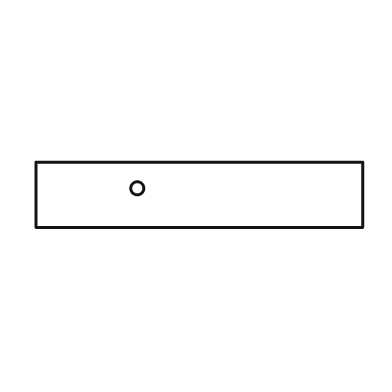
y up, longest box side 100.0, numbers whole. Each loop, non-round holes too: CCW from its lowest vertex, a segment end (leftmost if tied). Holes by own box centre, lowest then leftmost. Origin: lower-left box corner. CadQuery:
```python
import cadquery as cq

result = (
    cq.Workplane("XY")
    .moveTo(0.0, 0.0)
    .lineTo(100.0, 0.0)
    .lineTo(100.0, 20.0)
    .lineTo(0.0, 20.0)
    .close()
    .moveTo(31.0, 12.0)
    .circle(2.0)
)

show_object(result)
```